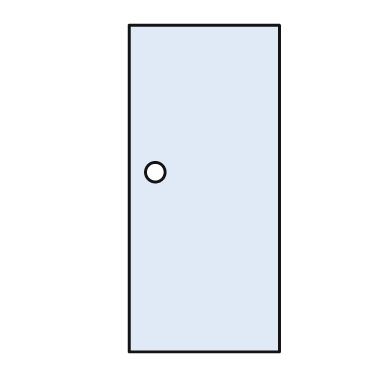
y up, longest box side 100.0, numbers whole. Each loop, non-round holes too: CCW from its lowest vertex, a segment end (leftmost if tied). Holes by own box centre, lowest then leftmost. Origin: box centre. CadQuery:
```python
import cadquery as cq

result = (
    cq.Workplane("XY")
    .moveTo(-23.0, -50.0)
    .lineTo(23.0, -50.0)
    .lineTo(23.0, 50.0)
    .lineTo(-23.0, 50.0)
    .close()
    .moveTo(-15.0, 5.0)
    .circle(3.0)
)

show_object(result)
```